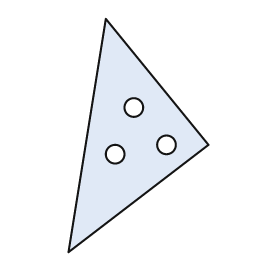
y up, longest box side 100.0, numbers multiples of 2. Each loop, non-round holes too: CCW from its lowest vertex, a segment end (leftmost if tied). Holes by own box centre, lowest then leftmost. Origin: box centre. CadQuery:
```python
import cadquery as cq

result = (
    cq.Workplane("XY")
    .moveTo(-30.0, -50.0)
    .lineTo(30.0, -4.0)
    .lineTo(-14.0, 50.0)
    .close()
    .moveTo(-10.0, -8.0)
    .circle(4.0)
    .moveTo(12.0, -4.0)
    .circle(4.0)
    .moveTo(-2.0, 12.0)
    .circle(4.0)
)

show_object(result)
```